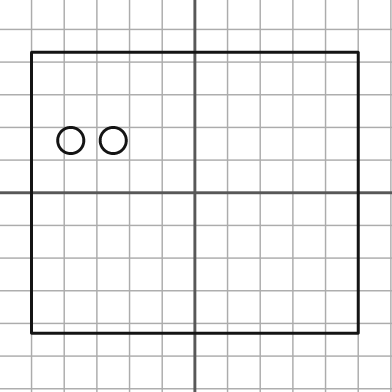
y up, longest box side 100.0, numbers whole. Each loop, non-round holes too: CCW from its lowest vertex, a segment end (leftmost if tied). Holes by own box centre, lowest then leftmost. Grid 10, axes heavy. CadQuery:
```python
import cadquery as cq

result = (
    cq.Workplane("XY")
    .moveTo(-50.0, -43.0)
    .lineTo(50.0, -43.0)
    .lineTo(50.0, 43.0)
    .lineTo(-50.0, 43.0)
    .close()
    .moveTo(-38.0, 16.0)
    .circle(4.0)
    .moveTo(-25.0, 16.0)
    .circle(4.0)
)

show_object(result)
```